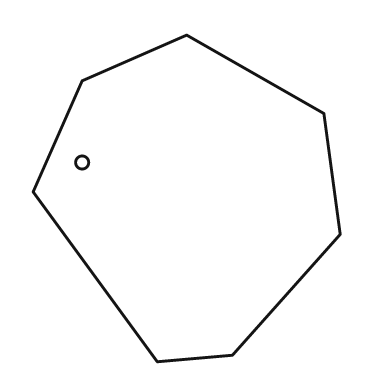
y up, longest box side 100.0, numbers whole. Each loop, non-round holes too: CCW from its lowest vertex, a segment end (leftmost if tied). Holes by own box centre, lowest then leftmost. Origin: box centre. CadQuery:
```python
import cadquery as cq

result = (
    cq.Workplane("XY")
    .moveTo(-9.0, -50.0)
    .lineTo(14.0, -48.0)
    .lineTo(47.0, -11.0)
    .lineTo(42.0, 26.0)
    .lineTo(0.0, 50.0)
    .lineTo(-32.0, 36.0)
    .lineTo(-47.0, 2.0)
    .close()
    .moveTo(-32.0, 11.0)
    .circle(2.0)
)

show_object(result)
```